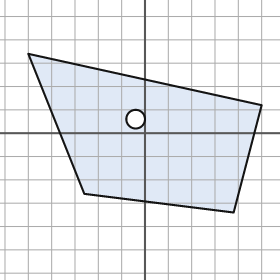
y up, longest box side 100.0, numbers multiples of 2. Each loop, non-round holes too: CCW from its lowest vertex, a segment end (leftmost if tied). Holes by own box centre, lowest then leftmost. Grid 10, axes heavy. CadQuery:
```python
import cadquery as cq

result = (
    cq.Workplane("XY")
    .moveTo(38.0, -34.0)
    .lineTo(50.0, 12.0)
    .lineTo(-50.0, 34.0)
    .lineTo(-26.0, -26.0)
    .close()
    .moveTo(-4.0, 6.0)
    .circle(4.0)
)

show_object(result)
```